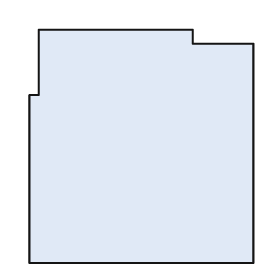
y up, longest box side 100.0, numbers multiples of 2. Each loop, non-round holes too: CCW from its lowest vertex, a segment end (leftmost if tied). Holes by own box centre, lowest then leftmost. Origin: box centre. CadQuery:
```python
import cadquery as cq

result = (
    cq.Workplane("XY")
    .moveTo(-48.0, -50.0)
    .lineTo(48.0, -50.0)
    .lineTo(48.0, 44.0)
    .lineTo(22.0, 44.0)
    .lineTo(22.0, 50.0)
    .lineTo(-44.0, 50.0)
    .lineTo(-44.0, 22.0)
    .lineTo(-48.0, 22.0)
    .close()
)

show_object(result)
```